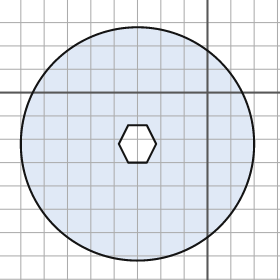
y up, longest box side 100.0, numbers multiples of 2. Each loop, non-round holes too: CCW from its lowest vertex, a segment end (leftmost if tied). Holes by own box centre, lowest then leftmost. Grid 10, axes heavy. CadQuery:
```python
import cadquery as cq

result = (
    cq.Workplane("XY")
    .moveTo(-30.0, -22.0)
    .circle(50.0)
    .moveTo(-34.0, -30.0)
    .lineTo(-26.0, -30.0)
    .lineTo(-22.0, -22.0)
    .lineTo(-26.0, -14.0)
    .lineTo(-34.0, -14.0)
    .lineTo(-38.0, -22.0)
    .close()
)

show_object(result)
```